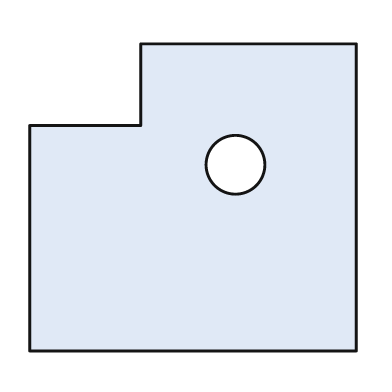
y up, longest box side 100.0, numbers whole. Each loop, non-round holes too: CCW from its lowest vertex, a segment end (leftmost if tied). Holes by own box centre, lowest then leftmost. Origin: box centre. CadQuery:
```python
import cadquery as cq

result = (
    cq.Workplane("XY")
    .moveTo(-50.0, -47.0)
    .lineTo(50.0, -47.0)
    .lineTo(50.0, 47.0)
    .lineTo(-16.0, 47.0)
    .lineTo(-16.0, 22.0)
    .lineTo(-50.0, 22.0)
    .close()
    .moveTo(13.0, 10.0)
    .circle(9.0)
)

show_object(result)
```